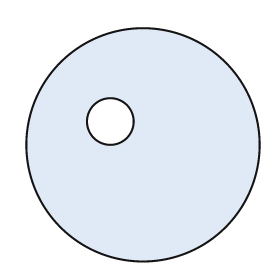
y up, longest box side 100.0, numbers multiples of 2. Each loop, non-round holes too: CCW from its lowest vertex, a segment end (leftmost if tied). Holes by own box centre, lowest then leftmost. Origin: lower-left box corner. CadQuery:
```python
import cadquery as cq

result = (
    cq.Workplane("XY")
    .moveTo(50.0, 50.0)
    .circle(50.0)
    .moveTo(36.0, 60.0)
    .circle(10.0)
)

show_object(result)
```